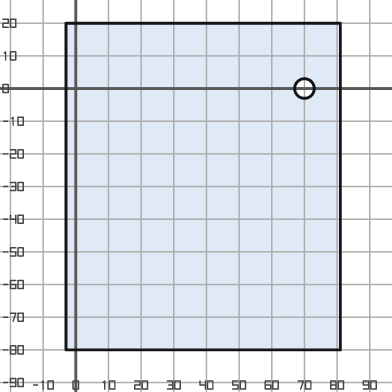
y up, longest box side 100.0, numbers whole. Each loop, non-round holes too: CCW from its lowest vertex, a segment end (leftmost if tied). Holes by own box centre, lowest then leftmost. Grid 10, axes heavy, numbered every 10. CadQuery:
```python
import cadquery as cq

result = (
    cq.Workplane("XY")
    .moveTo(-3.0, -80.0)
    .lineTo(81.0, -80.0)
    .lineTo(81.0, 20.0)
    .lineTo(-3.0, 20.0)
    .close()
    .moveTo(70.0, 0.0)
    .circle(3.0)
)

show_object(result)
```